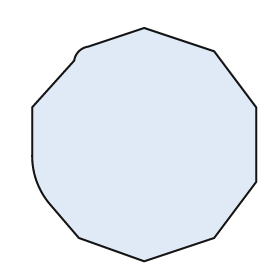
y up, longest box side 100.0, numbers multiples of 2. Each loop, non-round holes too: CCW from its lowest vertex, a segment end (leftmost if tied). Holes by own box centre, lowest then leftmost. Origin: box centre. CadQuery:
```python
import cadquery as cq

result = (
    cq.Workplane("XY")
    .moveTo(0.0, -50.0)
    .lineTo(30.0, -40.0)
    .lineTo(48.0, -16.0)
    .lineTo(48.0, 16.0)
    .lineTo(30.0, 40.0)
    .lineTo(0.0, 50.0)
    .lineTo(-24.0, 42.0)
    .threePointArc((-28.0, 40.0), (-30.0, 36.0))
    .lineTo(-48.0, 16.0)
    .lineTo(-48.0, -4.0)
    .threePointArc((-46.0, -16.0), (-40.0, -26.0))
    .lineTo(-28.0, -40.0)
    .close()
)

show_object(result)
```